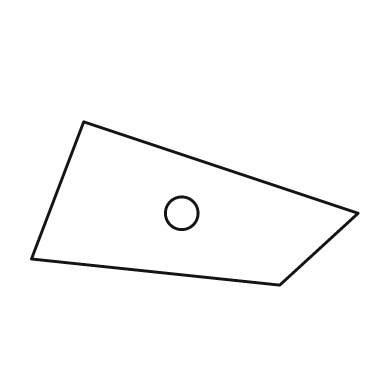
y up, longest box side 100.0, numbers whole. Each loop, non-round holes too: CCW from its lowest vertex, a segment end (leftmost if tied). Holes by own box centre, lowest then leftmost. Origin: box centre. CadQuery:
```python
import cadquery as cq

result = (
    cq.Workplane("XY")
    .moveTo(26.0, -25.0)
    .lineTo(50.0, -3.0)
    .lineTo(-34.0, 25.0)
    .lineTo(-50.0, -17.0)
    .close()
    .moveTo(-4.0, -3.0)
    .circle(5.0)
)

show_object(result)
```